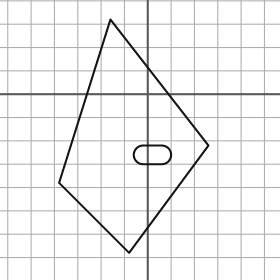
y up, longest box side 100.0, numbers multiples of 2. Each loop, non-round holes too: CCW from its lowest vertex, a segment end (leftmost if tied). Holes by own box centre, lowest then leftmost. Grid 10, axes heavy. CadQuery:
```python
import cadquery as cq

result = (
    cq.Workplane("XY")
    .moveTo(-8.0, -68.0)
    .lineTo(26.0, -22.0)
    .lineTo(-16.0, 32.0)
    .lineTo(-38.0, -38.0)
    .close()
    .moveTo(-2.0, -30.0)
    .lineTo(6.0, -30.0)
    .threePointArc((10.0, -26.0), (6.0, -22.0))
    .lineTo(-2.0, -22.0)
    .threePointArc((-6.0, -26.0), (-2.0, -30.0))
    .close()
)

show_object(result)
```